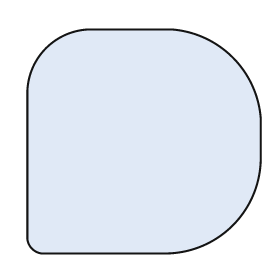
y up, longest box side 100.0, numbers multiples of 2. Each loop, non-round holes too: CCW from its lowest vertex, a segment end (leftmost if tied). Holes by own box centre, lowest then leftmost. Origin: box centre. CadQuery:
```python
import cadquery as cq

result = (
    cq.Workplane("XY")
    .moveTo(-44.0, -48.0)
    .lineTo(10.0, -48.0)
    .threePointArc((38.0, -36.0), (50.0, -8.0))
    .lineTo(50.0, 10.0)
    .threePointArc((38.0, 36.0), (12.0, 48.0))
    .lineTo(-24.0, 48.0)
    .threePointArc((-42.0, 40.0), (-50.0, 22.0))
    .lineTo(-50.0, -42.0)
    .threePointArc((-48.0, -46.0), (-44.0, -48.0))
    .close()
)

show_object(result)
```